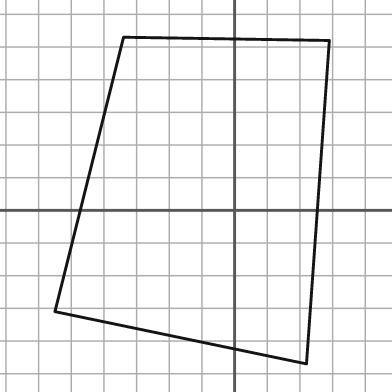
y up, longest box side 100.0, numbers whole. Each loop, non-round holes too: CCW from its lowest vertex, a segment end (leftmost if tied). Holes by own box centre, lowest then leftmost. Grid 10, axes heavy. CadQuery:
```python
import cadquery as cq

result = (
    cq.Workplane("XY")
    .moveTo(22.0, -47.0)
    .lineTo(29.0, 52.0)
    .lineTo(-34.0, 53.0)
    .lineTo(-55.0, -31.0)
    .close()
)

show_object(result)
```